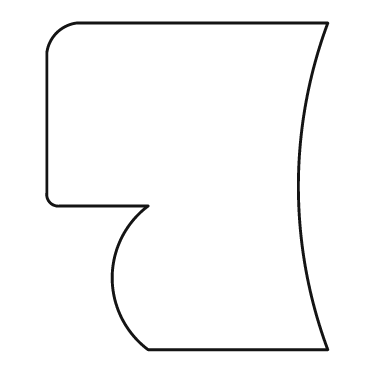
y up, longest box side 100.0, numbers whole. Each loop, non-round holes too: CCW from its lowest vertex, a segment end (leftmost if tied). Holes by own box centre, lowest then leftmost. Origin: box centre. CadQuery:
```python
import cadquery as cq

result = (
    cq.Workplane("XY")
    .moveTo(-12.0, -50.0)
    .lineTo(43.0, -50.0)
    .threePointArc((34.0, 0.0), (43.0, 50.0))
    .lineTo(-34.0, 50.0)
    .threePointArc((-40.0, 47.0), (-43.0, 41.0))
    .lineTo(-43.0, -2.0)
    .threePointArc((-42.0, -5.0), (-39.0, -6.0))
    .lineTo(-12.0, -6.0)
    .threePointArc((-23.0, -28.0), (-12.0, -50.0))
    .close()
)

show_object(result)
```